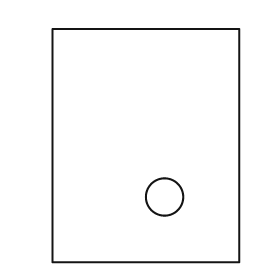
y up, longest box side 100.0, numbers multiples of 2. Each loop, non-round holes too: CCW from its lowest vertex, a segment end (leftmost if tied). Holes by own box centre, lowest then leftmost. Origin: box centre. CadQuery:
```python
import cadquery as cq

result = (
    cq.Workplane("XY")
    .moveTo(-40.0, -50.0)
    .lineTo(40.0, -50.0)
    .lineTo(40.0, 50.0)
    .lineTo(-40.0, 50.0)
    .close()
    .moveTo(8.0, -22.0)
    .circle(8.0)
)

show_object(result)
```